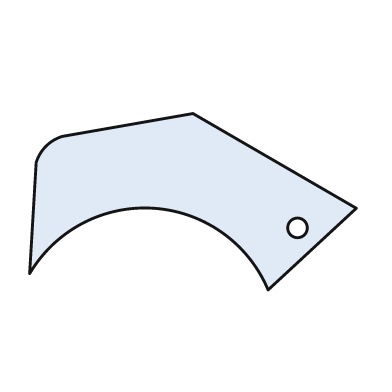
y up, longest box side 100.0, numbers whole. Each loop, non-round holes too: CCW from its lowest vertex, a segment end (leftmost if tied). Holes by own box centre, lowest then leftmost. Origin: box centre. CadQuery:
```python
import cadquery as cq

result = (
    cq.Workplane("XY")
    .moveTo(23.0, -27.0)
    .lineTo(50.0, -2.0)
    .lineTo(0.0, 27.0)
    .lineTo(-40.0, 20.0)
    .threePointArc((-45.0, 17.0), (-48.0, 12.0))
    .lineTo(-50.0, -22.0)
    .threePointArc((-12.0, -2.0), (23.0, -27.0))
    .close()
    .moveTo(32.0, -8.0)
    .circle(3.0)
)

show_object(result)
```